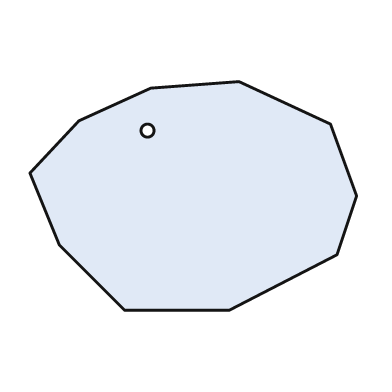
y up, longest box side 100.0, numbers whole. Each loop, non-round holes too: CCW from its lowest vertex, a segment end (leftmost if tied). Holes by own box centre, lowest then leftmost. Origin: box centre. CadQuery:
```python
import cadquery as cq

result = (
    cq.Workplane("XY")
    .moveTo(-21.0, -35.0)
    .lineTo(11.0, -35.0)
    .lineTo(44.0, -18.0)
    .lineTo(50.0, 0.0)
    .lineTo(42.0, 22.0)
    .lineTo(14.0, 35.0)
    .lineTo(-13.0, 33.0)
    .lineTo(-35.0, 23.0)
    .lineTo(-50.0, 7.0)
    .lineTo(-41.0, -15.0)
    .close()
    .moveTo(-14.0, 20.0)
    .circle(2.0)
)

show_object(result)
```